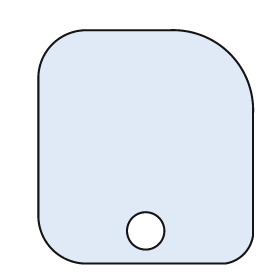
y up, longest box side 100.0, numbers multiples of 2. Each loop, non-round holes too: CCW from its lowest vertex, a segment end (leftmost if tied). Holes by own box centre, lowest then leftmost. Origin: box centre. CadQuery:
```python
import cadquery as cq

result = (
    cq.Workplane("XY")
    .moveTo(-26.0, -50.0)
    .lineTo(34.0, -50.0)
    .threePointArc((42.0, -46.0), (46.0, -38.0))
    .lineTo(46.0, 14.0)
    .threePointArc((36.0, 40.0), (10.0, 50.0))
    .lineTo(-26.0, 50.0)
    .threePointArc((-40.0, 44.0), (-46.0, 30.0))
    .lineTo(-46.0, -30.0)
    .threePointArc((-40.0, -44.0), (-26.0, -50.0))
    .close()
    .moveTo(0.0, -36.0)
    .circle(8.0)
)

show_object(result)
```